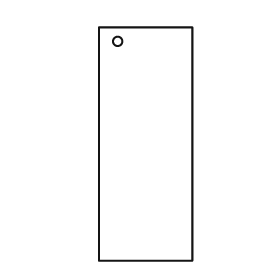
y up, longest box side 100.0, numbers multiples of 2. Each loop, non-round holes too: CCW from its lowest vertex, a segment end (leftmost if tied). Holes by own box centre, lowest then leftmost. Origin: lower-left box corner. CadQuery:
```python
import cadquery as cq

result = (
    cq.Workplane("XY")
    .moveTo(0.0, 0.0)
    .lineTo(40.0, 0.0)
    .lineTo(40.0, 100.0)
    .lineTo(0.0, 100.0)
    .close()
    .moveTo(8.0, 94.0)
    .circle(2.0)
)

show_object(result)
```